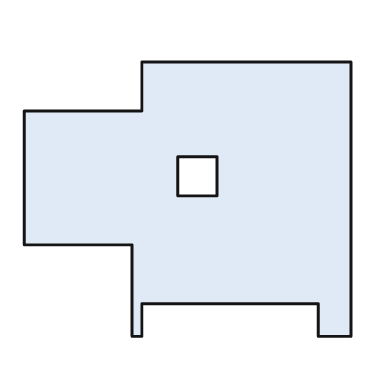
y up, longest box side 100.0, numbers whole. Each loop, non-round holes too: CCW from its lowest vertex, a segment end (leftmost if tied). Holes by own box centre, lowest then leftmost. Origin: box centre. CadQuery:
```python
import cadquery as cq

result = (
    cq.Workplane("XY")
    .moveTo(-17.0, -42.0)
    .lineTo(-14.0, -42.0)
    .lineTo(-14.0, -32.0)
    .lineTo(40.0, -32.0)
    .lineTo(40.0, -42.0)
    .lineTo(50.0, -42.0)
    .lineTo(50.0, 42.0)
    .lineTo(-14.0, 42.0)
    .lineTo(-14.0, 27.0)
    .lineTo(-50.0, 27.0)
    .lineTo(-50.0, -14.0)
    .lineTo(-17.0, -14.0)
    .close()
    .moveTo(-3.0, 1.0)
    .lineTo(9.0, 1.0)
    .lineTo(9.0, 13.0)
    .lineTo(-3.0, 13.0)
    .close()
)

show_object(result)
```